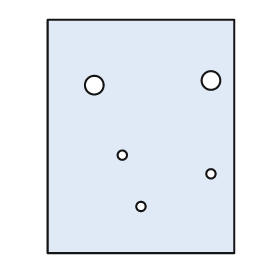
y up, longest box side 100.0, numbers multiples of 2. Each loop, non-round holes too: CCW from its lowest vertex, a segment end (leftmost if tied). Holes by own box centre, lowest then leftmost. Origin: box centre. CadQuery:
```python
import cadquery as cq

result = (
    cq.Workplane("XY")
    .moveTo(-40.0, -50.0)
    .lineTo(40.0, -50.0)
    .lineTo(40.0, 50.0)
    .lineTo(-40.0, 50.0)
    .close()
    .moveTo(0.0, -30.0)
    .circle(2.0)
    .moveTo(30.0, -16.0)
    .circle(2.0)
    .moveTo(-8.0, -8.0)
    .circle(2.0)
    .moveTo(-20.0, 22.0)
    .circle(4.0)
    .moveTo(30.0, 24.0)
    .circle(4.0)
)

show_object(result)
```